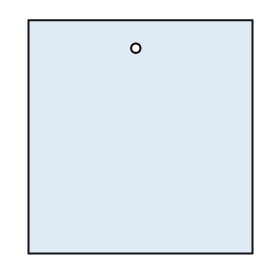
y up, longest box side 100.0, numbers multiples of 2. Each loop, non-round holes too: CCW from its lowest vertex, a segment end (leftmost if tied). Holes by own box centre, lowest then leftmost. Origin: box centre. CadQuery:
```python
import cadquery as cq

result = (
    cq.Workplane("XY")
    .moveTo(-48.0, -50.0)
    .lineTo(48.0, -50.0)
    .lineTo(48.0, 50.0)
    .lineTo(-48.0, 50.0)
    .close()
    .moveTo(-2.0, 38.0)
    .circle(2.0)
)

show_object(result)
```